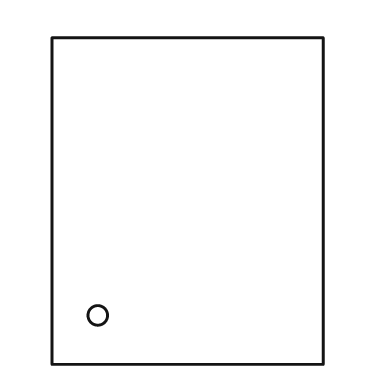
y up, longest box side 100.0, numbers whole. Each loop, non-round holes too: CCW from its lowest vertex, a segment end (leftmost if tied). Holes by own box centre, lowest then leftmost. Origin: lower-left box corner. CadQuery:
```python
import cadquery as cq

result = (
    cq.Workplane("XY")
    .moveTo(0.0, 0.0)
    .lineTo(83.0, 0.0)
    .lineTo(83.0, 100.0)
    .lineTo(0.0, 100.0)
    .close()
    .moveTo(14.0, 15.0)
    .circle(3.0)
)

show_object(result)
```